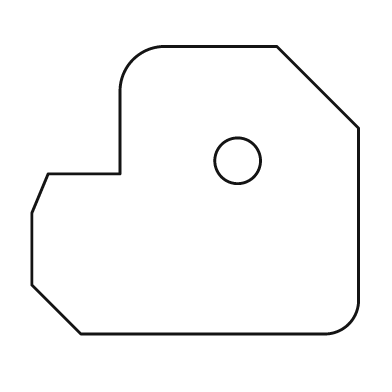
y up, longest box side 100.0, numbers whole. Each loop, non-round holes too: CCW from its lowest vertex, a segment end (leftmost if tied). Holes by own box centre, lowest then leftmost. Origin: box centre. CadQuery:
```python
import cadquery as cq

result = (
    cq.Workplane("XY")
    .moveTo(-35.0, -44.0)
    .lineTo(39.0, -44.0)
    .threePointArc((47.0, -41.0), (50.0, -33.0))
    .lineTo(50.0, 19.0)
    .lineTo(25.0, 44.0)
    .lineTo(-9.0, 44.0)
    .threePointArc((-19.0, 40.0), (-23.0, 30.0))
    .lineTo(-23.0, 5.0)
    .lineTo(-45.0, 5.0)
    .lineTo(-50.0, -7.0)
    .lineTo(-50.0, -29.0)
    .close()
    .moveTo(13.0, 9.0)
    .circle(7.0)
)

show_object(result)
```